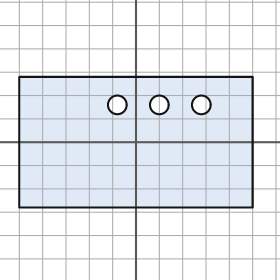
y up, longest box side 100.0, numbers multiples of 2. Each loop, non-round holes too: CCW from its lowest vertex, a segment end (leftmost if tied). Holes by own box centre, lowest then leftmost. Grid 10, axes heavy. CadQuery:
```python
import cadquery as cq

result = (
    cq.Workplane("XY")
    .moveTo(-50.0, -28.0)
    .lineTo(50.0, -28.0)
    .lineTo(50.0, 28.0)
    .lineTo(-50.0, 28.0)
    .close()
    .moveTo(-8.0, 16.0)
    .circle(4.0)
    .moveTo(10.0, 16.0)
    .circle(4.0)
    .moveTo(28.0, 16.0)
    .circle(4.0)
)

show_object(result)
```